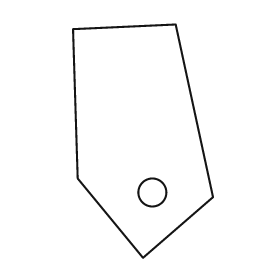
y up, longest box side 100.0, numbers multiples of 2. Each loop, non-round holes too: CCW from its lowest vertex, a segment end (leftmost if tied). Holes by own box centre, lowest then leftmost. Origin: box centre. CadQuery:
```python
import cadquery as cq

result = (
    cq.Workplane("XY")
    .moveTo(0.0, -50.0)
    .lineTo(30.0, -24.0)
    .lineTo(14.0, 50.0)
    .lineTo(-30.0, 48.0)
    .lineTo(-28.0, -16.0)
    .close()
    .moveTo(4.0, -22.0)
    .circle(6.0)
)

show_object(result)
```